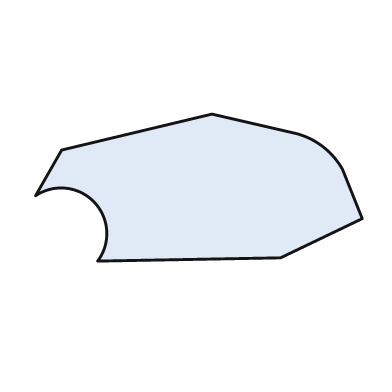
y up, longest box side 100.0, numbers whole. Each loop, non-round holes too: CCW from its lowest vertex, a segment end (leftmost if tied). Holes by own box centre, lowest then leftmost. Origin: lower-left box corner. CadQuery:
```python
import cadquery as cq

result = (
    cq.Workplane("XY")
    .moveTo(19.0, 0.0)
    .lineTo(75.0, 1.0)
    .lineTo(100.0, 13.0)
    .lineTo(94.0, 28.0)
    .threePointArc((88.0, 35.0), (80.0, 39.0))
    .lineTo(54.0, 45.0)
    .lineTo(8.0, 34.0)
    .lineTo(0.0, 20.0)
    .threePointArc((18.0, 18.0), (19.0, 0.0))
    .close()
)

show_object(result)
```